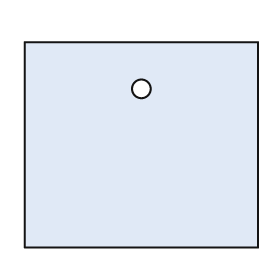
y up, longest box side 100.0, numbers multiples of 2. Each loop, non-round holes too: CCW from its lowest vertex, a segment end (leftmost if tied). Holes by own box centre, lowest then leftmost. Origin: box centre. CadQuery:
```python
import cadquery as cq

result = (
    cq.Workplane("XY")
    .moveTo(-50.0, -44.0)
    .lineTo(50.0, -44.0)
    .lineTo(50.0, 44.0)
    .lineTo(-50.0, 44.0)
    .close()
    .moveTo(0.0, 24.0)
    .circle(4.0)
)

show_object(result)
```